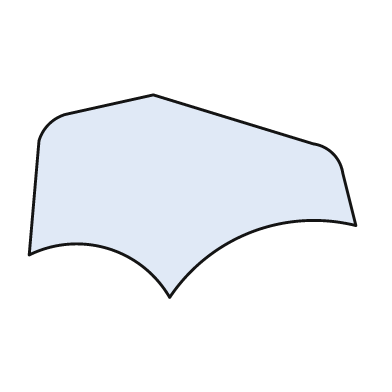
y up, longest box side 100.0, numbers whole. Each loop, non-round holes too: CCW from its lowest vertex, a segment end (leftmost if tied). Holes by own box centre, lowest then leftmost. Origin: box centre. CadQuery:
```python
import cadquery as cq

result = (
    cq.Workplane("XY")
    .moveTo(-7.0, -31.0)
    .threePointArc((18.0, -11.0), (50.0, -9.0))
    .lineTo(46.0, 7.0)
    .threePointArc((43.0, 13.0), (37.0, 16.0))
    .lineTo(-12.0, 31.0)
    .lineTo(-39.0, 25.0)
    .threePointArc((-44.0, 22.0), (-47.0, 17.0))
    .lineTo(-50.0, -18.0)
    .threePointArc((-26.0, -16.0), (-7.0, -31.0))
    .close()
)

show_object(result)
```